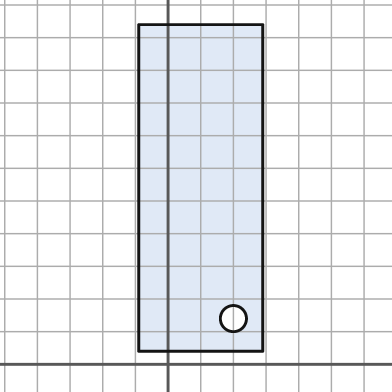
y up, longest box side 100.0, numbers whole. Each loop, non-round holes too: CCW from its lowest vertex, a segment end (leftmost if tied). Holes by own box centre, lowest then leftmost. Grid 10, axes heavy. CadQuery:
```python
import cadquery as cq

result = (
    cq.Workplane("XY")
    .moveTo(-9.0, 4.0)
    .lineTo(29.0, 4.0)
    .lineTo(29.0, 104.0)
    .lineTo(-9.0, 104.0)
    .close()
    .moveTo(20.0, 14.0)
    .circle(4.0)
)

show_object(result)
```